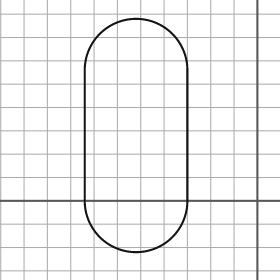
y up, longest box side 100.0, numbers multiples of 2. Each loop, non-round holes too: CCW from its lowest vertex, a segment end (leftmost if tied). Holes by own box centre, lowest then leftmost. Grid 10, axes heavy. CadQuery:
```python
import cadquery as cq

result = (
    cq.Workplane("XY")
    .moveTo(-74.0, 0.0)
    .threePointArc((-52.0, -22.0), (-30.0, 0.0))
    .lineTo(-30.0, 56.0)
    .threePointArc((-52.0, 78.0), (-74.0, 56.0))
    .close()
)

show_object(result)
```